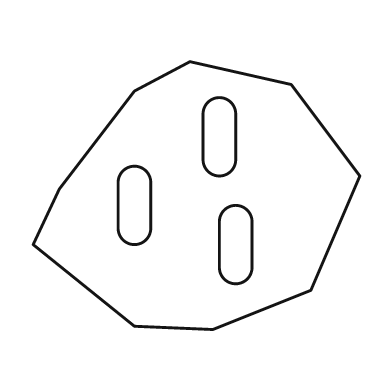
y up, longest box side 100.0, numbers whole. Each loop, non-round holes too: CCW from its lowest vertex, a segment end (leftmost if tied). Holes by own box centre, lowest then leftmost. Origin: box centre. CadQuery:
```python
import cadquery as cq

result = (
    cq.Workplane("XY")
    .moveTo(5.0, -41.0)
    .lineTo(35.0, -29.0)
    .lineTo(50.0, 6.0)
    .lineTo(29.0, 34.0)
    .lineTo(-2.0, 41.0)
    .lineTo(-19.0, 32.0)
    .lineTo(-42.0, 2.0)
    .lineTo(-50.0, -15.0)
    .lineTo(-19.0, -40.0)
    .close()
    .moveTo(7.0, -22.0)
    .threePointArc((12.0, -27.0), (17.0, -22.0))
    .lineTo(17.0, -8.0)
    .threePointArc((12.0, -3.0), (7.0, -8.0))
    .close()
    .moveTo(-24.0, -10.0)
    .threePointArc((-19.0, -15.0), (-14.0, -10.0))
    .lineTo(-14.0, 4.0)
    .threePointArc((-19.0, 9.0), (-24.0, 4.0))
    .close()
    .moveTo(2.0, 11.0)
    .threePointArc((7.0, 6.0), (12.0, 11.0))
    .lineTo(12.0, 25.0)
    .threePointArc((7.0, 30.0), (2.0, 25.0))
    .close()
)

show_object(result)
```